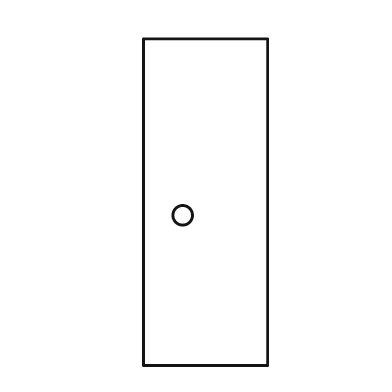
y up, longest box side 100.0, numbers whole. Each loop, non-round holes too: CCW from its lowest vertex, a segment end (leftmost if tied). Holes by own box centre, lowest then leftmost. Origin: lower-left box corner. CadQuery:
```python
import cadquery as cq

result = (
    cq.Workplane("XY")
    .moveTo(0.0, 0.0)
    .lineTo(38.0, 0.0)
    .lineTo(38.0, 100.0)
    .lineTo(0.0, 100.0)
    .close()
    .moveTo(12.0, 46.0)
    .circle(3.0)
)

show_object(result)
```